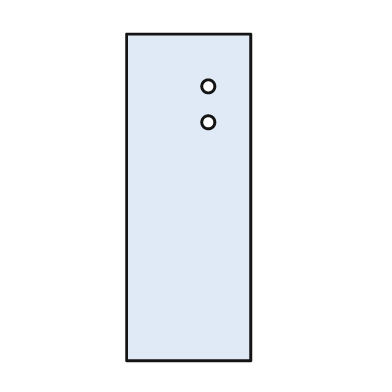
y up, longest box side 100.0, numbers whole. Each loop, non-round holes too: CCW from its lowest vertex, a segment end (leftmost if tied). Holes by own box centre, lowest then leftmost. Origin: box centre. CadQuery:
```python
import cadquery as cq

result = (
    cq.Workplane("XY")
    .moveTo(-19.0, -50.0)
    .lineTo(19.0, -50.0)
    .lineTo(19.0, 50.0)
    .lineTo(-19.0, 50.0)
    .close()
    .moveTo(6.0, 23.0)
    .circle(2.0)
    .moveTo(6.0, 34.0)
    .circle(2.0)
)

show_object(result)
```